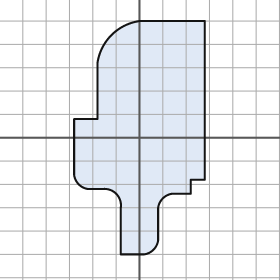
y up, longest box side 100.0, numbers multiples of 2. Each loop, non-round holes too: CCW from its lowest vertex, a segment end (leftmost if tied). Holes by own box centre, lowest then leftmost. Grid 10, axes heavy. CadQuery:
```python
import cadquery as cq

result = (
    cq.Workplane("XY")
    .moveTo(-8.0, -50.0)
    .lineTo(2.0, -50.0)
    .threePointArc((6.0, -48.0), (8.0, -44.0))
    .lineTo(8.0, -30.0)
    .threePointArc((10.0, -26.0), (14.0, -24.0))
    .lineTo(22.0, -24.0)
    .lineTo(22.0, -18.0)
    .lineTo(28.0, -18.0)
    .lineTo(28.0, 50.0)
    .lineTo(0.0, 50.0)
    .threePointArc((-12.0, 44.0), (-18.0, 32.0))
    .lineTo(-18.0, 8.0)
    .lineTo(-28.0, 8.0)
    .lineTo(-28.0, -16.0)
    .threePointArc((-26.0, -20.0), (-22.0, -22.0))
    .lineTo(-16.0, -22.0)
    .threePointArc((-10.0, -24.0), (-8.0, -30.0))
    .close()
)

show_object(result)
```